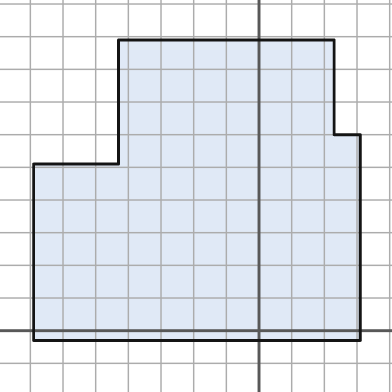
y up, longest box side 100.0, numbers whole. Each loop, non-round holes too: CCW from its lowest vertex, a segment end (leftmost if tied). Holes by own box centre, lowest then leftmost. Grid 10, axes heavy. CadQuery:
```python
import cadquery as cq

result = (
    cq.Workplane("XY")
    .moveTo(-69.0, -3.0)
    .lineTo(31.0, -3.0)
    .lineTo(31.0, 60.0)
    .lineTo(23.0, 60.0)
    .lineTo(23.0, 89.0)
    .lineTo(-43.0, 89.0)
    .lineTo(-43.0, 51.0)
    .lineTo(-69.0, 51.0)
    .close()
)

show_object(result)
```